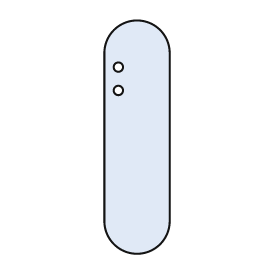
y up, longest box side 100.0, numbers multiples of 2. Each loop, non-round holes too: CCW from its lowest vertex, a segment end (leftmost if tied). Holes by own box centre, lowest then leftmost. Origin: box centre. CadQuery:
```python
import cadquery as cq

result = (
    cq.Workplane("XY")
    .moveTo(-14.0, -36.0)
    .threePointArc((0.0, -50.0), (14.0, -36.0))
    .lineTo(14.0, 36.0)
    .threePointArc((0.0, 50.0), (-14.0, 36.0))
    .close()
    .moveTo(-8.0, 20.0)
    .circle(2.0)
    .moveTo(-8.0, 30.0)
    .circle(2.0)
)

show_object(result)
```